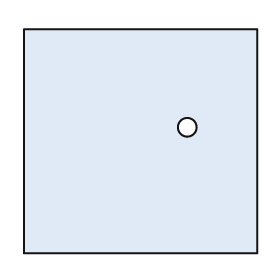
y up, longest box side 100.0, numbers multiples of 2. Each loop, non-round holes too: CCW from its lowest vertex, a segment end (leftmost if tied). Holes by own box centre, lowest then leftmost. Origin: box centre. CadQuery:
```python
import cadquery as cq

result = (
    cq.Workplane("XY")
    .moveTo(-50.0, -48.0)
    .lineTo(50.0, -48.0)
    .lineTo(50.0, 48.0)
    .lineTo(-50.0, 48.0)
    .close()
    .moveTo(20.0, 6.0)
    .circle(4.0)
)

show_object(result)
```